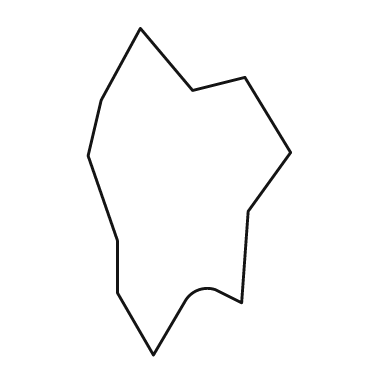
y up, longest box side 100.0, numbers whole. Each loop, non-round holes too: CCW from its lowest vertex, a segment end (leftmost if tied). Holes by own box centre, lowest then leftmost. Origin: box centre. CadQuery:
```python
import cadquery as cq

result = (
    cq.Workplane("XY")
    .moveTo(-11.0, -50.0)
    .lineTo(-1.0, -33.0)
    .threePointArc((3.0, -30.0), (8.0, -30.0))
    .lineTo(16.0, -34.0)
    .lineTo(18.0, -6.0)
    .lineTo(31.0, 12.0)
    .lineTo(17.0, 35.0)
    .lineTo(1.0, 31.0)
    .lineTo(-15.0, 50.0)
    .lineTo(-27.0, 28.0)
    .lineTo(-31.0, 11.0)
    .lineTo(-22.0, -15.0)
    .lineTo(-22.0, -31.0)
    .close()
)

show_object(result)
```